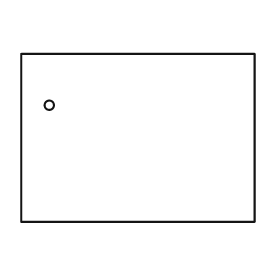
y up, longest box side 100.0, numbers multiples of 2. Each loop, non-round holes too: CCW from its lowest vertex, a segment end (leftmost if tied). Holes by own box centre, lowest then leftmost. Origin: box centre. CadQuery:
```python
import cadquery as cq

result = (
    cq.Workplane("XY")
    .moveTo(-50.0, -36.0)
    .lineTo(50.0, -36.0)
    .lineTo(50.0, 36.0)
    .lineTo(-50.0, 36.0)
    .close()
    .moveTo(-38.0, 14.0)
    .circle(2.0)
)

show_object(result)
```